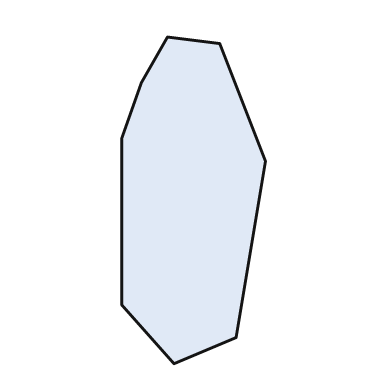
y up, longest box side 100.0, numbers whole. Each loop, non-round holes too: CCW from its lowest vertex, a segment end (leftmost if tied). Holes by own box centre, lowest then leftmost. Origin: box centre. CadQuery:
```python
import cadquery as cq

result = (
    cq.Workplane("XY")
    .moveTo(-6.0, -50.0)
    .lineTo(13.0, -42.0)
    .lineTo(22.0, 12.0)
    .lineTo(8.0, 48.0)
    .lineTo(-8.0, 50.0)
    .lineTo(-16.0, 36.0)
    .lineTo(-22.0, 19.0)
    .lineTo(-22.0, -32.0)
    .close()
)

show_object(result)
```